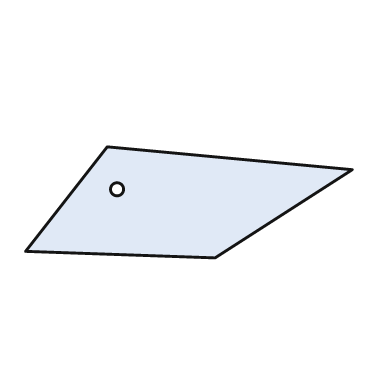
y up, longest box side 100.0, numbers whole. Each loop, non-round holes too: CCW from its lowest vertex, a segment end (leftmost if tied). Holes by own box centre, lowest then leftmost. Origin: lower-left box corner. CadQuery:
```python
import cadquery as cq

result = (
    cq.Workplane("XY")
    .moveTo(58.0, 0.0)
    .lineTo(100.0, 27.0)
    .lineTo(25.0, 34.0)
    .lineTo(0.0, 2.0)
    .close()
    .moveTo(28.0, 21.0)
    .circle(2.0)
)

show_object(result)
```